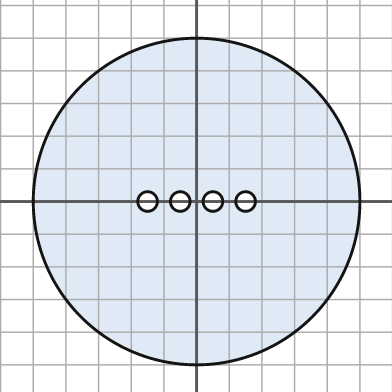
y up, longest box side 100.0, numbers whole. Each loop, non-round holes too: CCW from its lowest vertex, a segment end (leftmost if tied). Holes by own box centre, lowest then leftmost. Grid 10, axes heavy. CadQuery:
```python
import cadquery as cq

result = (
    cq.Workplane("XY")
    .moveTo(0.0, 0.0)
    .circle(50.0)
    .moveTo(-15.0, 0.0)
    .circle(3.0)
    .moveTo(-5.0, 0.0)
    .circle(3.0)
    .moveTo(5.0, 0.0)
    .circle(3.0)
    .moveTo(15.0, 0.0)
    .circle(3.0)
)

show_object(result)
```